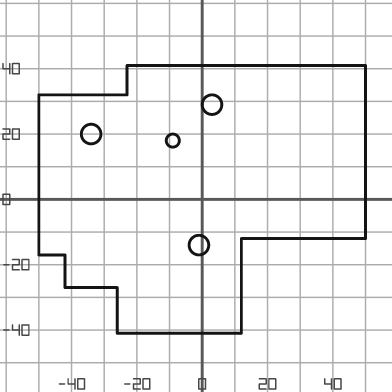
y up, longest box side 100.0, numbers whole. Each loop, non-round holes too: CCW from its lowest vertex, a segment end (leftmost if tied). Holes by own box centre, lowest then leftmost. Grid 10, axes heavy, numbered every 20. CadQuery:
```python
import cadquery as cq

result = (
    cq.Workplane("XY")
    .moveTo(-26.0, -41.0)
    .lineTo(12.0, -41.0)
    .lineTo(12.0, -12.0)
    .lineTo(50.0, -12.0)
    .lineTo(50.0, 41.0)
    .lineTo(-23.0, 41.0)
    .lineTo(-23.0, 32.0)
    .lineTo(-50.0, 32.0)
    .lineTo(-50.0, -17.0)
    .lineTo(-42.0, -17.0)
    .lineTo(-42.0, -27.0)
    .lineTo(-26.0, -27.0)
    .close()
    .moveTo(-1.0, -14.0)
    .circle(3.0)
    .moveTo(-9.0, 18.0)
    .circle(2.0)
    .moveTo(-34.0, 20.0)
    .circle(3.0)
    .moveTo(3.0, 29.0)
    .circle(3.0)
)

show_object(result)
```